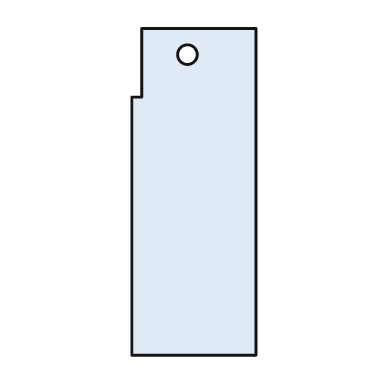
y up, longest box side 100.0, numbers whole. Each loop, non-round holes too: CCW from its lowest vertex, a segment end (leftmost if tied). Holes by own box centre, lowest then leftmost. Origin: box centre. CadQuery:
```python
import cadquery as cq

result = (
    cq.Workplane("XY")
    .moveTo(-19.0, -50.0)
    .lineTo(19.0, -50.0)
    .lineTo(19.0, 50.0)
    .lineTo(-16.0, 50.0)
    .lineTo(-16.0, 29.0)
    .lineTo(-19.0, 29.0)
    .close()
    .moveTo(-2.0, 42.0)
    .circle(3.0)
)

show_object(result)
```